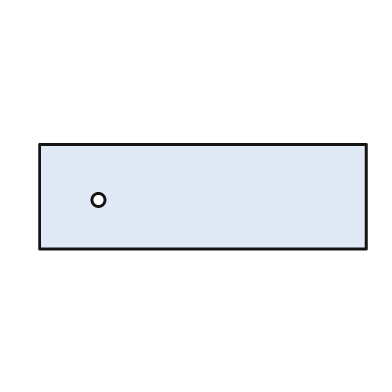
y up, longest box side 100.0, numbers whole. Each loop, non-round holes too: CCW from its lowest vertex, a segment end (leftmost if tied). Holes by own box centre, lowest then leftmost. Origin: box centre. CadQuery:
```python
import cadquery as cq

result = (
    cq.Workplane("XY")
    .moveTo(-50.0, -16.0)
    .lineTo(50.0, -16.0)
    .lineTo(50.0, 16.0)
    .lineTo(-50.0, 16.0)
    .close()
    .moveTo(-32.0, -1.0)
    .circle(2.0)
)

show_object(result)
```